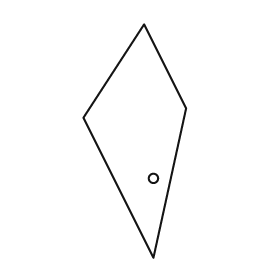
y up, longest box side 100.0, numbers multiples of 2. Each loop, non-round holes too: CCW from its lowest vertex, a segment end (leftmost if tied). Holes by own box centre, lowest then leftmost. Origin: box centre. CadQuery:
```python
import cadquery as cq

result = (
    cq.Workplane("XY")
    .moveTo(8.0, -50.0)
    .lineTo(22.0, 14.0)
    .lineTo(4.0, 50.0)
    .lineTo(-22.0, 10.0)
    .close()
    .moveTo(8.0, -16.0)
    .circle(2.0)
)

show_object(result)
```